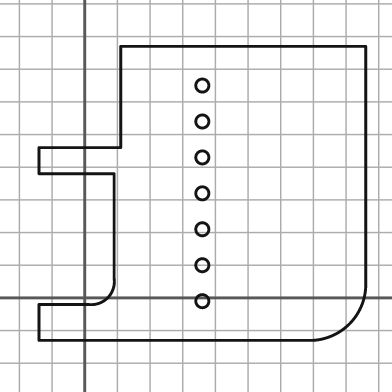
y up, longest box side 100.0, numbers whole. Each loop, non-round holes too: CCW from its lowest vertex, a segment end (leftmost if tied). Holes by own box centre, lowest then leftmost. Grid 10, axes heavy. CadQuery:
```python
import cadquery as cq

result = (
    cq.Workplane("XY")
    .moveTo(-14.0, -13.0)
    .lineTo(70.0, -13.0)
    .threePointArc((81.0, -8.0), (86.0, 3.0))
    .lineTo(86.0, 77.0)
    .lineTo(11.0, 77.0)
    .lineTo(11.0, 46.0)
    .lineTo(-14.0, 46.0)
    .lineTo(-14.0, 38.0)
    .lineTo(9.0, 38.0)
    .lineTo(9.0, 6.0)
    .threePointArc((7.0, 0.0), (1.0, -2.0))
    .lineTo(-14.0, -2.0)
    .close()
    .moveTo(36.0, -1.0)
    .circle(2.0)
    .moveTo(36.0, 10.0)
    .circle(2.0)
    .moveTo(36.0, 21.0)
    .circle(2.0)
    .moveTo(36.0, 32.0)
    .circle(2.0)
    .moveTo(36.0, 43.0)
    .circle(2.0)
    .moveTo(36.0, 54.0)
    .circle(2.0)
    .moveTo(36.0, 65.0)
    .circle(2.0)
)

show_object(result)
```